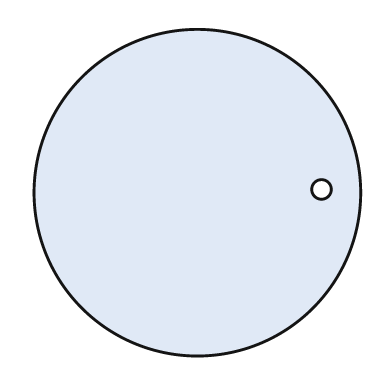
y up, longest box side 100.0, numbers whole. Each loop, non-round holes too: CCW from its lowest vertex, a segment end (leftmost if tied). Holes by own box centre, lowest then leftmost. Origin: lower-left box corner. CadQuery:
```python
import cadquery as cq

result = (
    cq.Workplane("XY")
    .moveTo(50.0, 50.0)
    .circle(50.0)
    .moveTo(88.0, 51.0)
    .circle(3.0)
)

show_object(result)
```